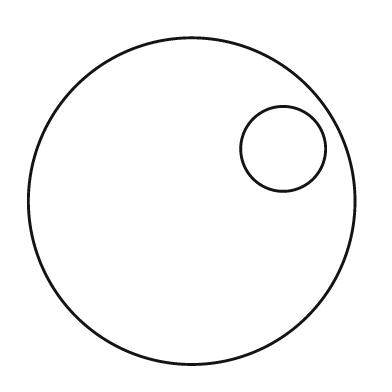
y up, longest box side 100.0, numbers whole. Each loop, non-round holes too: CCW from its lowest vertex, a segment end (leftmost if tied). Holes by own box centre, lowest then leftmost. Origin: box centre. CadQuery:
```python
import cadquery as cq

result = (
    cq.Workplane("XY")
    .moveTo(0.0, 0.0)
    .circle(50.0)
    .moveTo(28.0, 16.0)
    .circle(13.0)
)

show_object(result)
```